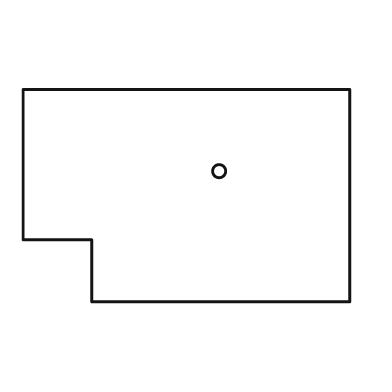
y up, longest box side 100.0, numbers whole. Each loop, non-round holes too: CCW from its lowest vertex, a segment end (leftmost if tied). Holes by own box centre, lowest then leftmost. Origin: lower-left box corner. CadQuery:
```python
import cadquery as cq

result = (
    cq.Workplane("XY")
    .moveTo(21.0, 0.0)
    .lineTo(100.0, 0.0)
    .lineTo(100.0, 65.0)
    .lineTo(0.0, 65.0)
    .lineTo(0.0, 19.0)
    .lineTo(21.0, 19.0)
    .close()
    .moveTo(60.0, 40.0)
    .circle(2.0)
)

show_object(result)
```